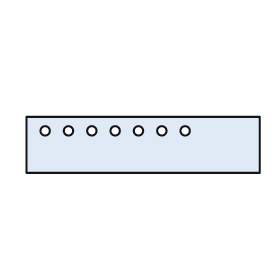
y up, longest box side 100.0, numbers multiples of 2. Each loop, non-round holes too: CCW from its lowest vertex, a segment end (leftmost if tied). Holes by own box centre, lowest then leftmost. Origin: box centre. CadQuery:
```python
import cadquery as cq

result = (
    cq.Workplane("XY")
    .moveTo(-50.0, -12.0)
    .lineTo(50.0, -12.0)
    .lineTo(50.0, 12.0)
    .lineTo(-50.0, 12.0)
    .close()
    .moveTo(-42.0, 6.0)
    .circle(2.0)
    .moveTo(-32.0, 6.0)
    .circle(2.0)
    .moveTo(-22.0, 6.0)
    .circle(2.0)
    .moveTo(-12.0, 6.0)
    .circle(2.0)
    .moveTo(-2.0, 6.0)
    .circle(2.0)
    .moveTo(8.0, 6.0)
    .circle(2.0)
    .moveTo(18.0, 6.0)
    .circle(2.0)
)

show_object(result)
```